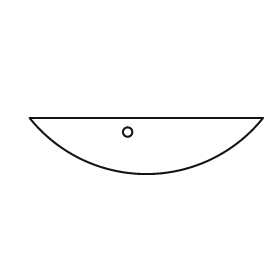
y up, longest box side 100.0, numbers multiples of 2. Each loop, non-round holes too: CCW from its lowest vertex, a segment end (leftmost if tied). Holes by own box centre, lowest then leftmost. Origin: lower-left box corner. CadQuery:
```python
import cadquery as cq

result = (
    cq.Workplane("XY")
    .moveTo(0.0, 24.0)
    .threePointArc((50.0, 0.0), (100.0, 24.0))
    .close()
    .moveTo(42.0, 18.0)
    .circle(2.0)
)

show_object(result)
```